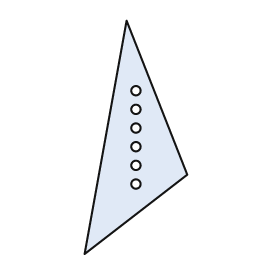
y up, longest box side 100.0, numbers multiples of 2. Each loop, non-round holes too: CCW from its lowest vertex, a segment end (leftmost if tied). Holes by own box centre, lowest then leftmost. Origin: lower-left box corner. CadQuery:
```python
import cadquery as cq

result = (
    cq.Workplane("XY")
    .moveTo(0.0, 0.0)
    .lineTo(44.0, 34.0)
    .lineTo(18.0, 100.0)
    .close()
    .moveTo(22.0, 30.0)
    .circle(2.0)
    .moveTo(22.0, 38.0)
    .circle(2.0)
    .moveTo(22.0, 46.0)
    .circle(2.0)
    .moveTo(22.0, 54.0)
    .circle(2.0)
    .moveTo(22.0, 62.0)
    .circle(2.0)
    .moveTo(22.0, 70.0)
    .circle(2.0)
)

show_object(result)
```